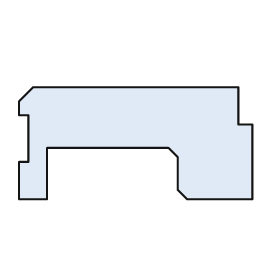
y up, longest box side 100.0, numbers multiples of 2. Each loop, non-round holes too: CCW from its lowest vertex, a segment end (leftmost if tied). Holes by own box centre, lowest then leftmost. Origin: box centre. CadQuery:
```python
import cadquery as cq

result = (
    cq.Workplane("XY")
    .moveTo(-50.0, -24.0)
    .lineTo(-38.0, -24.0)
    .lineTo(-38.0, -2.0)
    .lineTo(14.0, -2.0)
    .lineTo(18.0, -6.0)
    .lineTo(18.0, -20.0)
    .lineTo(22.0, -24.0)
    .lineTo(50.0, -24.0)
    .lineTo(50.0, 8.0)
    .lineTo(44.0, 8.0)
    .lineTo(44.0, 24.0)
    .lineTo(-44.0, 24.0)
    .lineTo(-50.0, 18.0)
    .lineTo(-50.0, 12.0)
    .lineTo(-46.0, 12.0)
    .lineTo(-46.0, -8.0)
    .lineTo(-50.0, -8.0)
    .close()
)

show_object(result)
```